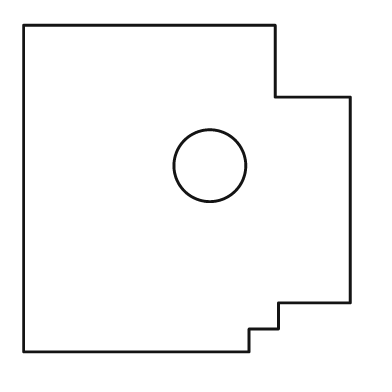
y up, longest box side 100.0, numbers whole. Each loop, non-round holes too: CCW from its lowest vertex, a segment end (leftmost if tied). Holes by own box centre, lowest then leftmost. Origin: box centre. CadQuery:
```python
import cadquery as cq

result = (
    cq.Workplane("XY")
    .moveTo(-50.0, -50.0)
    .lineTo(19.0, -50.0)
    .lineTo(19.0, -43.0)
    .lineTo(28.0, -43.0)
    .lineTo(28.0, -35.0)
    .lineTo(50.0, -35.0)
    .lineTo(50.0, 28.0)
    .lineTo(27.0, 28.0)
    .lineTo(27.0, 50.0)
    .lineTo(-50.0, 50.0)
    .close()
    .moveTo(7.0, 7.0)
    .circle(11.0)
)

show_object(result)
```